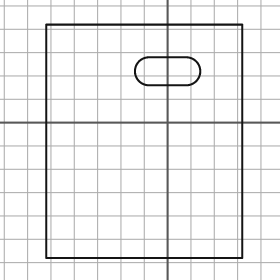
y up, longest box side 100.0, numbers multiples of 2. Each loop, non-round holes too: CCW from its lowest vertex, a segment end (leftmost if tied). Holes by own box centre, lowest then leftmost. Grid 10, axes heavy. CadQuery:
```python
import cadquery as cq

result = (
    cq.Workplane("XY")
    .moveTo(-52.0, -58.0)
    .lineTo(32.0, -58.0)
    .lineTo(32.0, 42.0)
    .lineTo(-52.0, 42.0)
    .close()
    .moveTo(-8.0, 16.0)
    .lineTo(8.0, 16.0)
    .threePointArc((14.0, 22.0), (8.0, 28.0))
    .lineTo(-8.0, 28.0)
    .threePointArc((-14.0, 22.0), (-8.0, 16.0))
    .close()
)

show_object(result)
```